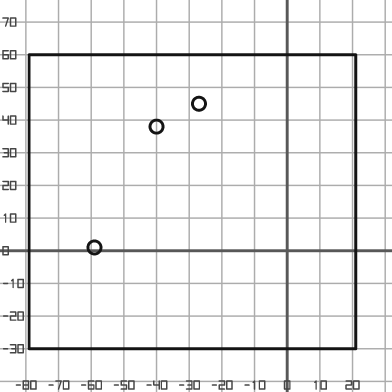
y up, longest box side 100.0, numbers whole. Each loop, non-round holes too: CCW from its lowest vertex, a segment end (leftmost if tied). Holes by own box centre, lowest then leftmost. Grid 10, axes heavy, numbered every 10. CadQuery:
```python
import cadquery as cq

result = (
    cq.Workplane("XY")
    .moveTo(-79.0, -30.0)
    .lineTo(21.0, -30.0)
    .lineTo(21.0, 60.0)
    .lineTo(-79.0, 60.0)
    .close()
    .moveTo(-59.0, 1.0)
    .circle(2.0)
    .moveTo(-40.0, 38.0)
    .circle(2.0)
    .moveTo(-27.0, 45.0)
    .circle(2.0)
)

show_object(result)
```